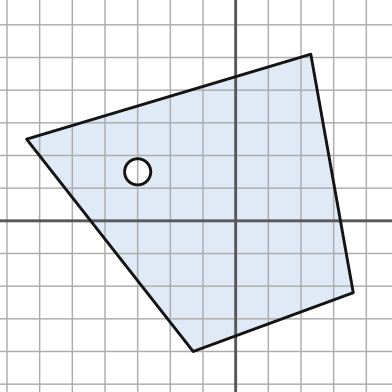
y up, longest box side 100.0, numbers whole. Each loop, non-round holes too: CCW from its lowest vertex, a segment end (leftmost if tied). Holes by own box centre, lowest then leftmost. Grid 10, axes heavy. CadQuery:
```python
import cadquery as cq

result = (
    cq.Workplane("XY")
    .moveTo(-13.0, -40.0)
    .lineTo(36.0, -22.0)
    .lineTo(23.0, 51.0)
    .lineTo(-64.0, 25.0)
    .close()
    .moveTo(-30.0, 15.0)
    .circle(4.0)
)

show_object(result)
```